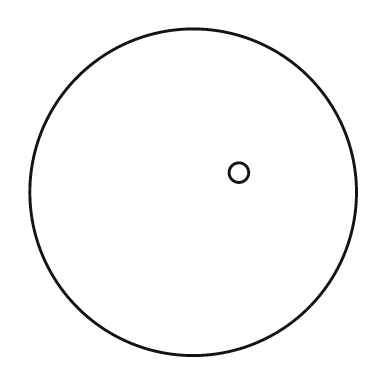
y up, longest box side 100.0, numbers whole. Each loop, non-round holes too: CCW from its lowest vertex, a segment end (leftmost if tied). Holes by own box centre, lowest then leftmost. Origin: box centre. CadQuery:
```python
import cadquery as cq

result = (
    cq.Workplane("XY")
    .moveTo(0.0, 0.0)
    .circle(50.0)
    .moveTo(14.0, 6.0)
    .circle(3.0)
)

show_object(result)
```